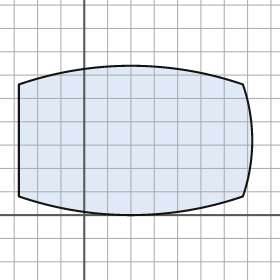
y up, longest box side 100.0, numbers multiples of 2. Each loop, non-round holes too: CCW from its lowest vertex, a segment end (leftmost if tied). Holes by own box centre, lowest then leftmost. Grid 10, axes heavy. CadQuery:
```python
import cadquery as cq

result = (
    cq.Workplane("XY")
    .moveTo(-28.0, 8.0)
    .threePointArc((20.0, 0.0), (68.0, 8.0))
    .threePointArc((72.0, 32.0), (68.0, 56.0))
    .threePointArc((20.0, 64.0), (-28.0, 56.0))
    .close()
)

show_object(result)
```